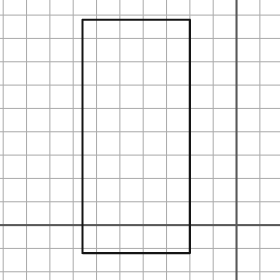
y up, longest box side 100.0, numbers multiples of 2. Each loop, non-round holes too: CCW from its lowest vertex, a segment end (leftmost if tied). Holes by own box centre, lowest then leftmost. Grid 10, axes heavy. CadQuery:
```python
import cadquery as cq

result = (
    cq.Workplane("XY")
    .moveTo(-66.0, -12.0)
    .lineTo(-20.0, -12.0)
    .lineTo(-20.0, 88.0)
    .lineTo(-66.0, 88.0)
    .close()
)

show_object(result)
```